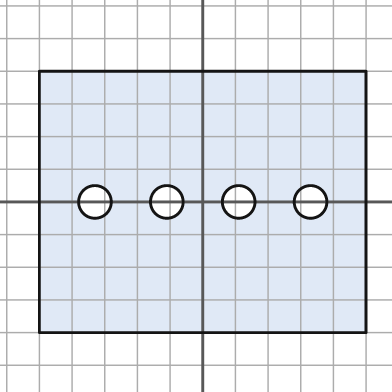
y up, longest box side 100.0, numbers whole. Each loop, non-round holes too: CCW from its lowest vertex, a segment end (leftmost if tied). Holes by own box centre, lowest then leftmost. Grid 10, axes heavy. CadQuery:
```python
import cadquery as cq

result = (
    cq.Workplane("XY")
    .moveTo(-50.0, -40.0)
    .lineTo(50.0, -40.0)
    .lineTo(50.0, 40.0)
    .lineTo(-50.0, 40.0)
    .close()
    .moveTo(-33.0, 0.0)
    .circle(5.0)
    .moveTo(-11.0, 0.0)
    .circle(5.0)
    .moveTo(11.0, 0.0)
    .circle(5.0)
    .moveTo(33.0, 0.0)
    .circle(5.0)
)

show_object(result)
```